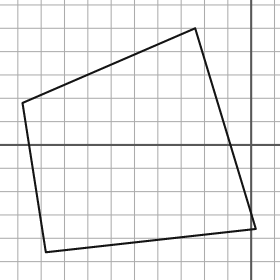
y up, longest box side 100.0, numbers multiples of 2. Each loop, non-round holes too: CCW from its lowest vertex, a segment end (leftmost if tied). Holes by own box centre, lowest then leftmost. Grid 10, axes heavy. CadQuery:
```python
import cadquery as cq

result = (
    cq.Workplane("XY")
    .moveTo(-88.0, -46.0)
    .lineTo(2.0, -36.0)
    .lineTo(-24.0, 50.0)
    .lineTo(-98.0, 18.0)
    .close()
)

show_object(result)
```